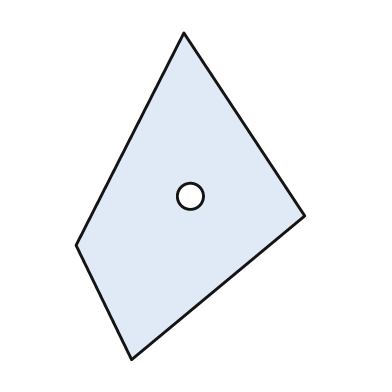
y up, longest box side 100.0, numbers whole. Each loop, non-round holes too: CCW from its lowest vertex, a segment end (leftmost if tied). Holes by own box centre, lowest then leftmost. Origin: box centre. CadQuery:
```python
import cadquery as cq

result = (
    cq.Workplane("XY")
    .moveTo(-18.0, -50.0)
    .lineTo(35.0, -6.0)
    .lineTo(-2.0, 50.0)
    .lineTo(-35.0, -15.0)
    .close()
    .moveTo(0.0, 0.0)
    .circle(4.0)
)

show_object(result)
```